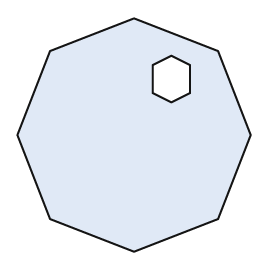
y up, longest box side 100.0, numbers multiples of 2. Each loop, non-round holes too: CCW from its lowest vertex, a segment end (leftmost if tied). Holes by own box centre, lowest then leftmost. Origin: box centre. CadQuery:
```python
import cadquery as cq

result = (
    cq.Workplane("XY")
    .moveTo(0.0, -50.0)
    .lineTo(36.0, -36.0)
    .lineTo(50.0, 0.0)
    .lineTo(36.0, 36.0)
    .lineTo(0.0, 50.0)
    .lineTo(-36.0, 36.0)
    .lineTo(-50.0, 0.0)
    .lineTo(-36.0, -36.0)
    .close()
    .moveTo(16.0, 14.0)
    .lineTo(24.0, 18.0)
    .lineTo(24.0, 30.0)
    .lineTo(16.0, 34.0)
    .lineTo(8.0, 30.0)
    .lineTo(8.0, 18.0)
    .close()
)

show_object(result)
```